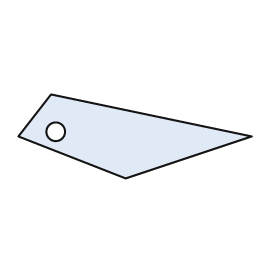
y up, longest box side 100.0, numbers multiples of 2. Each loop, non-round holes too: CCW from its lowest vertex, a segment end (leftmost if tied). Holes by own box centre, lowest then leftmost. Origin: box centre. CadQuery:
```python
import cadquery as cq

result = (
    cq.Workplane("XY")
    .moveTo(-4.0, -18.0)
    .lineTo(50.0, 0.0)
    .lineTo(-36.0, 18.0)
    .lineTo(-50.0, 0.0)
    .close()
    .moveTo(-34.0, 2.0)
    .circle(4.0)
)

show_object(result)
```